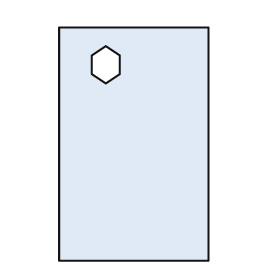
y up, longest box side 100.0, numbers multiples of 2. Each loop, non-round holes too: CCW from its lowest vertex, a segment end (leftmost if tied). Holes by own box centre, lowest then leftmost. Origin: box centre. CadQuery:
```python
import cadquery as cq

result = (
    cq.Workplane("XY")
    .moveTo(-32.0, -50.0)
    .lineTo(32.0, -50.0)
    .lineTo(32.0, 50.0)
    .lineTo(-32.0, 50.0)
    .close()
    .moveTo(-12.0, 26.0)
    .lineTo(-6.0, 30.0)
    .lineTo(-6.0, 38.0)
    .lineTo(-12.0, 42.0)
    .lineTo(-18.0, 38.0)
    .lineTo(-18.0, 30.0)
    .close()
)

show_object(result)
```